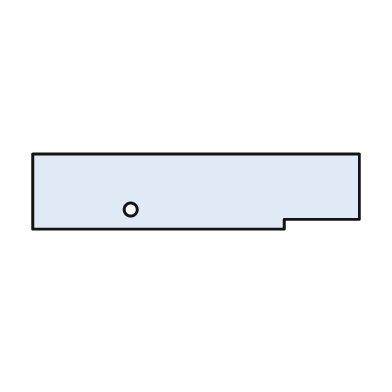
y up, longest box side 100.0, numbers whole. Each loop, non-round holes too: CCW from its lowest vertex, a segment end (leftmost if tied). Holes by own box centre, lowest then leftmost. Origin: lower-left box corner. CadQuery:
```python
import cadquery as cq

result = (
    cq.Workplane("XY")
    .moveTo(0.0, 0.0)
    .lineTo(77.0, 0.0)
    .lineTo(77.0, 3.0)
    .lineTo(100.0, 3.0)
    .lineTo(100.0, 23.0)
    .lineTo(0.0, 23.0)
    .close()
    .moveTo(30.0, 6.0)
    .circle(2.0)
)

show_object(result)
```